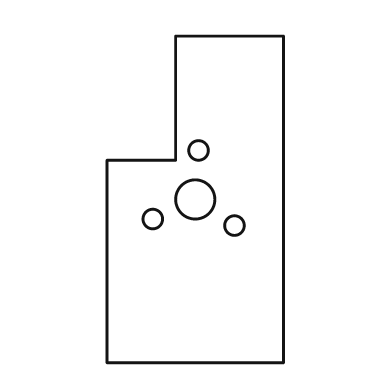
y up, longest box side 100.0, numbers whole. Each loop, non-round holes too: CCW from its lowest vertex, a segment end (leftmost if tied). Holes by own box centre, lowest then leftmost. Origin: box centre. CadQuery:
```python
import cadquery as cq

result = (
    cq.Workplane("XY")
    .moveTo(-27.0, -50.0)
    .lineTo(27.0, -50.0)
    .lineTo(27.0, 50.0)
    .lineTo(-6.0, 50.0)
    .lineTo(-6.0, 12.0)
    .lineTo(-27.0, 12.0)
    .close()
    .moveTo(12.0, -8.0)
    .circle(3.0)
    .moveTo(-13.0, -6.0)
    .circle(3.0)
    .moveTo(0.0, 0.0)
    .circle(6.0)
    .moveTo(1.0, 15.0)
    .circle(3.0)
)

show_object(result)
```